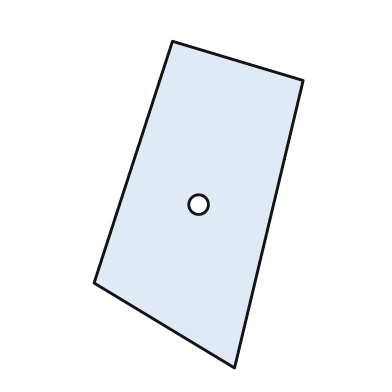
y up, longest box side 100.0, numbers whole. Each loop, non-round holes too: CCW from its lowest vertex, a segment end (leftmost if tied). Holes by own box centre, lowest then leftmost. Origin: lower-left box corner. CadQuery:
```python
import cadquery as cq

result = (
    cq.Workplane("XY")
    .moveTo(43.0, 0.0)
    .lineTo(64.0, 88.0)
    .lineTo(24.0, 100.0)
    .lineTo(0.0, 26.0)
    .close()
    .moveTo(32.0, 50.0)
    .circle(3.0)
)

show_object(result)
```